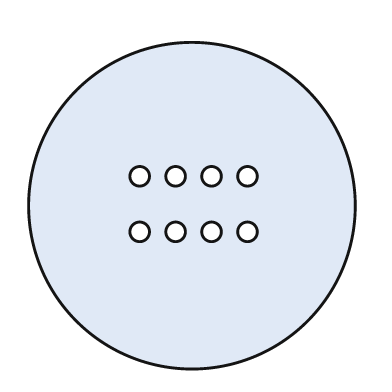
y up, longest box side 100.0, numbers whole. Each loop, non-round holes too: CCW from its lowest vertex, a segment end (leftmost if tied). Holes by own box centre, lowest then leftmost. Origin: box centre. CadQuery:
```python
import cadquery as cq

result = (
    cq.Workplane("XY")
    .moveTo(0.0, 0.0)
    .circle(50.0)
    .moveTo(-16.0, -8.0)
    .circle(3.0)
    .moveTo(-5.0, -8.0)
    .circle(3.0)
    .moveTo(6.0, -8.0)
    .circle(3.0)
    .moveTo(17.0, -8.0)
    .circle(3.0)
    .moveTo(-16.0, 9.0)
    .circle(3.0)
    .moveTo(-5.0, 9.0)
    .circle(3.0)
    .moveTo(6.0, 9.0)
    .circle(3.0)
    .moveTo(17.0, 9.0)
    .circle(3.0)
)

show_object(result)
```